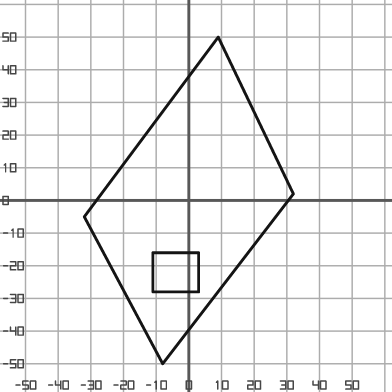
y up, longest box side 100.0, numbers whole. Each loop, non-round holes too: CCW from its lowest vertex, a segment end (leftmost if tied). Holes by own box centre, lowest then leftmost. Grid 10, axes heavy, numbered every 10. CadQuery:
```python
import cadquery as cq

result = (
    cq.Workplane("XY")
    .moveTo(-8.0, -50.0)
    .lineTo(32.0, 2.0)
    .lineTo(9.0, 50.0)
    .lineTo(-32.0, -5.0)
    .close()
    .moveTo(-11.0, -28.0)
    .lineTo(3.0, -28.0)
    .lineTo(3.0, -16.0)
    .lineTo(-11.0, -16.0)
    .close()
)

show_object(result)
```